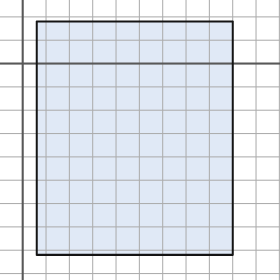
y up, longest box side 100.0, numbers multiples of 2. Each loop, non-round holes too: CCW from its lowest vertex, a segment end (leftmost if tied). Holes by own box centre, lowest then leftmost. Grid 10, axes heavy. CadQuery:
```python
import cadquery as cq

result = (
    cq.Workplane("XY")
    .moveTo(6.0, -82.0)
    .lineTo(90.0, -82.0)
    .lineTo(90.0, 18.0)
    .lineTo(6.0, 18.0)
    .close()
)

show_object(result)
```